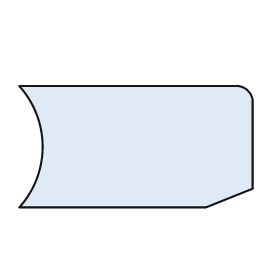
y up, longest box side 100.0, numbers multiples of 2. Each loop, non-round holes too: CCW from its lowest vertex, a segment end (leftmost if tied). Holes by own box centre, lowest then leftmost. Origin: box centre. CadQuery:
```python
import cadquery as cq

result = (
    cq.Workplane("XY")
    .moveTo(-50.0, -26.0)
    .lineTo(30.0, -26.0)
    .lineTo(50.0, -18.0)
    .lineTo(50.0, 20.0)
    .threePointArc((48.0, 24.0), (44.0, 26.0))
    .lineTo(-50.0, 26.0)
    .threePointArc((-40.0, 0.0), (-50.0, -26.0))
    .close()
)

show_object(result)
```